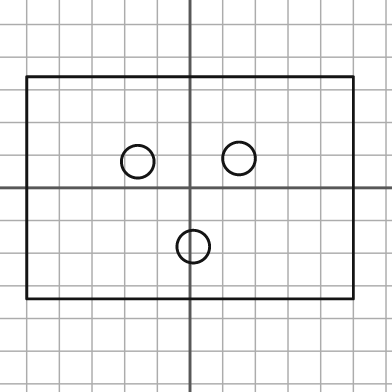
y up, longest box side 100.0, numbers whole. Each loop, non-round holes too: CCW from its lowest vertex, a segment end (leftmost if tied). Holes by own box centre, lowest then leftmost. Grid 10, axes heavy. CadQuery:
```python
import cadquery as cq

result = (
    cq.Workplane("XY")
    .moveTo(-50.0, -34.0)
    .lineTo(50.0, -34.0)
    .lineTo(50.0, 34.0)
    .lineTo(-50.0, 34.0)
    .close()
    .moveTo(1.0, -18.0)
    .circle(5.0)
    .moveTo(-16.0, 8.0)
    .circle(5.0)
    .moveTo(15.0, 9.0)
    .circle(5.0)
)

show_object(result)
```